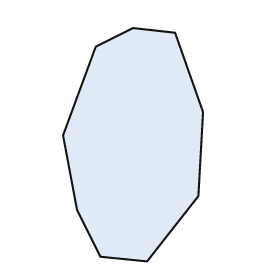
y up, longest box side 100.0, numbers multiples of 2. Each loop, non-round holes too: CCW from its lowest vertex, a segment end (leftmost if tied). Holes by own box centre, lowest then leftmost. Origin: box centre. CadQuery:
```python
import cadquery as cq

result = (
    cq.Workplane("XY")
    .moveTo(6.0, -50.0)
    .lineTo(28.0, -22.0)
    .lineTo(30.0, 14.0)
    .lineTo(18.0, 48.0)
    .lineTo(0.0, 50.0)
    .lineTo(-16.0, 42.0)
    .lineTo(-30.0, 4.0)
    .lineTo(-24.0, -28.0)
    .lineTo(-14.0, -48.0)
    .close()
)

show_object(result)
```